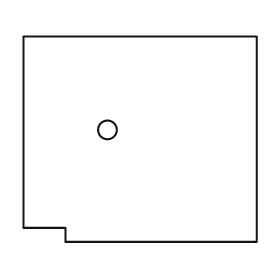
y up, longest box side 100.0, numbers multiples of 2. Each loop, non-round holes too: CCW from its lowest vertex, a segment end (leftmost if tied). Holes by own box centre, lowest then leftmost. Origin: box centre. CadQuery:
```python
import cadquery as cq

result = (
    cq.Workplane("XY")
    .moveTo(-32.0, -44.0)
    .lineTo(50.0, -44.0)
    .lineTo(50.0, 44.0)
    .lineTo(-50.0, 44.0)
    .lineTo(-50.0, -38.0)
    .lineTo(-32.0, -38.0)
    .close()
    .moveTo(-14.0, 4.0)
    .circle(4.0)
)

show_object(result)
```